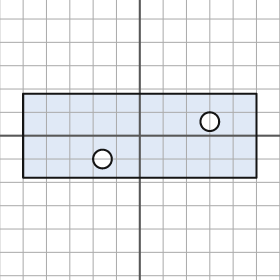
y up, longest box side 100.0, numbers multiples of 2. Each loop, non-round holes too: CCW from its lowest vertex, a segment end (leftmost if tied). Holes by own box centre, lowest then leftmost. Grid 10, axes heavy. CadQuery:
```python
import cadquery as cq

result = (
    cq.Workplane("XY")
    .moveTo(-50.0, -18.0)
    .lineTo(50.0, -18.0)
    .lineTo(50.0, 18.0)
    .lineTo(-50.0, 18.0)
    .close()
    .moveTo(-16.0, -10.0)
    .circle(4.0)
    .moveTo(30.0, 6.0)
    .circle(4.0)
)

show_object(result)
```